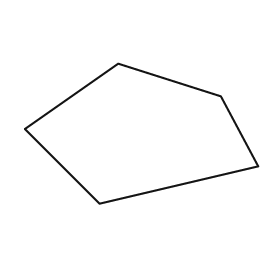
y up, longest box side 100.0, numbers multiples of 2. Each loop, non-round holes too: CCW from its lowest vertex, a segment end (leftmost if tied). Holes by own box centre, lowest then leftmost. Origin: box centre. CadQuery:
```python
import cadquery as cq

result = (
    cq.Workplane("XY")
    .moveTo(-18.0, -30.0)
    .lineTo(50.0, -14.0)
    .lineTo(34.0, 16.0)
    .lineTo(-10.0, 30.0)
    .lineTo(-50.0, 2.0)
    .close()
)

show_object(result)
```